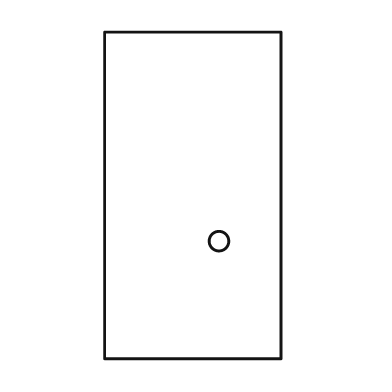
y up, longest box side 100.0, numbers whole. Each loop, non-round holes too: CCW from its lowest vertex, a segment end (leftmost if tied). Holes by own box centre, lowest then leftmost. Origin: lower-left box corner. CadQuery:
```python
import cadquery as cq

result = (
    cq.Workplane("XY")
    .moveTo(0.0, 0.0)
    .lineTo(54.0, 0.0)
    .lineTo(54.0, 100.0)
    .lineTo(0.0, 100.0)
    .close()
    .moveTo(35.0, 36.0)
    .circle(3.0)
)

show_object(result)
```